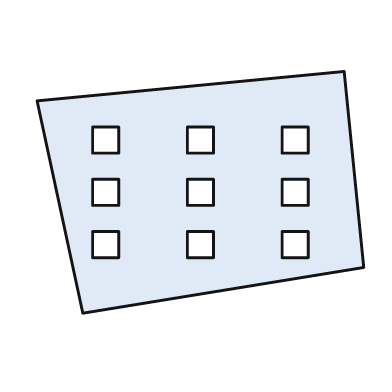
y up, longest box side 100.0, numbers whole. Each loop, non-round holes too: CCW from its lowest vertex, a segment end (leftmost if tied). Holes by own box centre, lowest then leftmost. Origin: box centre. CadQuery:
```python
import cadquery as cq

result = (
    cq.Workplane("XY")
    .moveTo(-36.0, -37.0)
    .lineTo(50.0, -23.0)
    .lineTo(44.0, 37.0)
    .lineTo(-50.0, 28.0)
    .close()
    .moveTo(-33.0, -20.0)
    .lineTo(-25.0, -20.0)
    .lineTo(-25.0, -12.0)
    .lineTo(-33.0, -12.0)
    .close()
    .moveTo(-4.0, -20.0)
    .lineTo(4.0, -20.0)
    .lineTo(4.0, -12.0)
    .lineTo(-4.0, -12.0)
    .close()
    .moveTo(25.0, -20.0)
    .lineTo(33.0, -20.0)
    .lineTo(33.0, -12.0)
    .lineTo(25.0, -12.0)
    .close()
    .moveTo(-33.0, -4.0)
    .lineTo(-25.0, -4.0)
    .lineTo(-25.0, 4.0)
    .lineTo(-33.0, 4.0)
    .close()
    .moveTo(-4.0, -4.0)
    .lineTo(4.0, -4.0)
    .lineTo(4.0, 4.0)
    .lineTo(-4.0, 4.0)
    .close()
    .moveTo(25.0, -4.0)
    .lineTo(33.0, -4.0)
    .lineTo(33.0, 4.0)
    .lineTo(25.0, 4.0)
    .close()
    .moveTo(-33.0, 12.0)
    .lineTo(-25.0, 12.0)
    .lineTo(-25.0, 20.0)
    .lineTo(-33.0, 20.0)
    .close()
    .moveTo(-4.0, 12.0)
    .lineTo(4.0, 12.0)
    .lineTo(4.0, 20.0)
    .lineTo(-4.0, 20.0)
    .close()
    .moveTo(25.0, 12.0)
    .lineTo(33.0, 12.0)
    .lineTo(33.0, 20.0)
    .lineTo(25.0, 20.0)
    .close()
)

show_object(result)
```